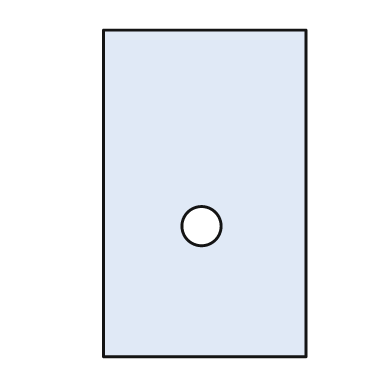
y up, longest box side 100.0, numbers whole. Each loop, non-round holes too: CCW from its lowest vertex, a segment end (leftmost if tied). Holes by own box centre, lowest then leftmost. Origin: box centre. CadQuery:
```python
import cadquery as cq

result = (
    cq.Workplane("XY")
    .moveTo(-31.0, -50.0)
    .lineTo(31.0, -50.0)
    .lineTo(31.0, 50.0)
    .lineTo(-31.0, 50.0)
    .close()
    .moveTo(-1.0, -10.0)
    .circle(6.0)
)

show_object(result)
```